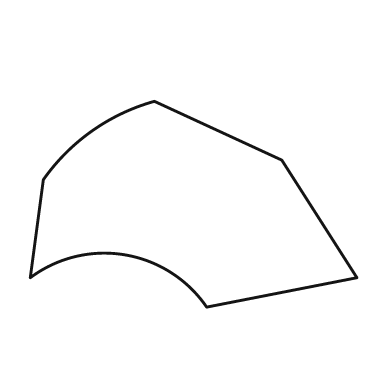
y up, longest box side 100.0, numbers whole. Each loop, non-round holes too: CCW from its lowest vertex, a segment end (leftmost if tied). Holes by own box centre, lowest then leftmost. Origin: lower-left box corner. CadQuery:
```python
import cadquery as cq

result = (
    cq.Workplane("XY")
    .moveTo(54.0, 0.0)
    .lineTo(100.0, 9.0)
    .lineTo(77.0, 45.0)
    .lineTo(38.0, 63.0)
    .threePointArc((19.0, 54.0), (4.0, 39.0))
    .lineTo(0.0, 9.0)
    .threePointArc((29.0, 16.0), (54.0, 0.0))
    .close()
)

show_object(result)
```